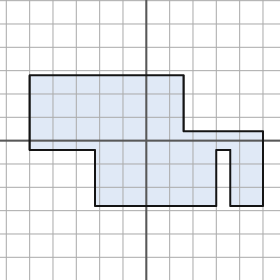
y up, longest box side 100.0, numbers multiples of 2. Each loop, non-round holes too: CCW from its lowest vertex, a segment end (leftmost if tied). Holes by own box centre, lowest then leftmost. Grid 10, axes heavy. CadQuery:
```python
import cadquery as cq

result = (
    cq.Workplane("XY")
    .moveTo(-22.0, -28.0)
    .lineTo(30.0, -28.0)
    .lineTo(30.0, -4.0)
    .lineTo(36.0, -4.0)
    .lineTo(36.0, -28.0)
    .lineTo(50.0, -28.0)
    .lineTo(50.0, 4.0)
    .lineTo(16.0, 4.0)
    .lineTo(16.0, 28.0)
    .lineTo(-50.0, 28.0)
    .lineTo(-50.0, -4.0)
    .lineTo(-22.0, -4.0)
    .close()
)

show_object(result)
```